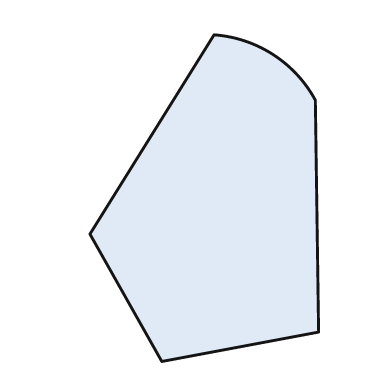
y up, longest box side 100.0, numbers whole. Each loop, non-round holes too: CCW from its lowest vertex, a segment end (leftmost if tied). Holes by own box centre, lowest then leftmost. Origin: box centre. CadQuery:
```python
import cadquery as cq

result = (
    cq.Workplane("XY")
    .moveTo(-13.0, -50.0)
    .lineTo(35.0, -41.0)
    .lineTo(34.0, 30.0)
    .threePointArc((21.0, 44.0), (3.0, 50.0))
    .lineTo(-35.0, -11.0)
    .close()
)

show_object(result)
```